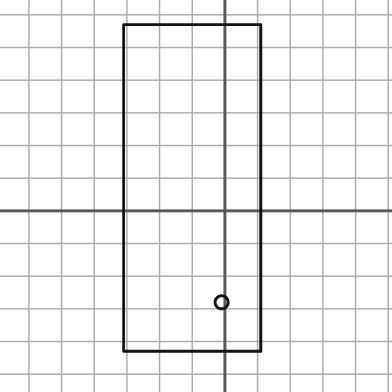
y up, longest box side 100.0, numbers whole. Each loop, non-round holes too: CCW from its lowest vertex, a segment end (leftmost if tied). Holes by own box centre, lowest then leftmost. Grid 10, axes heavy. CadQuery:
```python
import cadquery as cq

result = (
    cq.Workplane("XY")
    .moveTo(-31.0, -43.0)
    .lineTo(11.0, -43.0)
    .lineTo(11.0, 57.0)
    .lineTo(-31.0, 57.0)
    .close()
    .moveTo(-1.0, -28.0)
    .circle(2.0)
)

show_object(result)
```